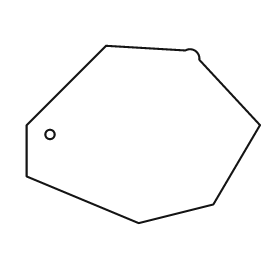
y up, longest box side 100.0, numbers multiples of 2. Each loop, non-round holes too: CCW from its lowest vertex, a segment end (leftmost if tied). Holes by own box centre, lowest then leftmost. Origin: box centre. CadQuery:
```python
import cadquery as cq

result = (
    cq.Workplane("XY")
    .moveTo(-2.0, -38.0)
    .lineTo(30.0, -30.0)
    .lineTo(50.0, 4.0)
    .lineTo(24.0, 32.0)
    .threePointArc((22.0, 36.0), (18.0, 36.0))
    .lineTo(-16.0, 38.0)
    .lineTo(-50.0, 4.0)
    .lineTo(-50.0, -18.0)
    .close()
    .moveTo(-40.0, 0.0)
    .circle(2.0)
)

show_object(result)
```